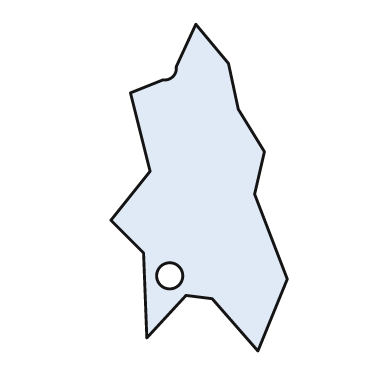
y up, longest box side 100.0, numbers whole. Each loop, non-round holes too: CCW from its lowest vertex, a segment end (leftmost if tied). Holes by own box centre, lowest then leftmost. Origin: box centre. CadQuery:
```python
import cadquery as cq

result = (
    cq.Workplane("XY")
    .moveTo(18.0, -50.0)
    .lineTo(27.0, -28.0)
    .lineTo(17.0, -2.0)
    .lineTo(20.0, 11.0)
    .lineTo(12.0, 24.0)
    .lineTo(9.0, 38.0)
    .lineTo(-1.0, 50.0)
    .lineTo(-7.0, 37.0)
    .threePointArc((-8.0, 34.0), (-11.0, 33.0))
    .lineTo(-21.0, 29.0)
    .lineTo(-15.0, 5.0)
    .lineTo(-27.0, -10.0)
    .lineTo(-17.0, -20.0)
    .lineTo(-16.0, -46.0)
    .lineTo(-4.0, -33.0)
    .lineTo(4.0, -34.0)
    .close()
    .moveTo(-9.0, -27.0)
    .circle(4.0)
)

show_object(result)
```